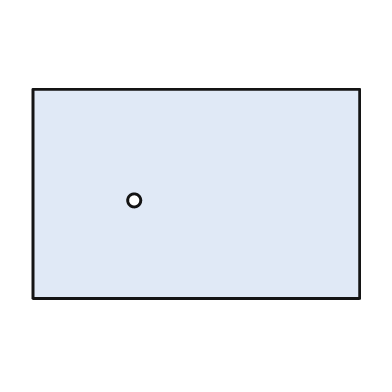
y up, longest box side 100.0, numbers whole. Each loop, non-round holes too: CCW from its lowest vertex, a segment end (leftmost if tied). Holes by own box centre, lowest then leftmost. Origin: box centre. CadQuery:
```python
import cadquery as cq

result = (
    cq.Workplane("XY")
    .moveTo(-50.0, -32.0)
    .lineTo(50.0, -32.0)
    .lineTo(50.0, 32.0)
    .lineTo(-50.0, 32.0)
    .close()
    .moveTo(-19.0, -2.0)
    .circle(2.0)
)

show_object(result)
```